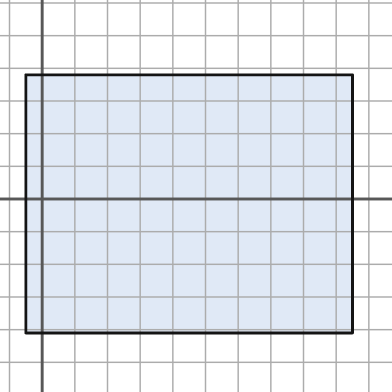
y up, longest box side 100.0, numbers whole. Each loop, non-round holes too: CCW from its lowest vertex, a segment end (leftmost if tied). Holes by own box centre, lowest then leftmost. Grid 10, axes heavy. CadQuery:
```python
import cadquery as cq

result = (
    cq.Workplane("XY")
    .moveTo(-5.0, -41.0)
    .lineTo(95.0, -41.0)
    .lineTo(95.0, 38.0)
    .lineTo(-5.0, 38.0)
    .close()
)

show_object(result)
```